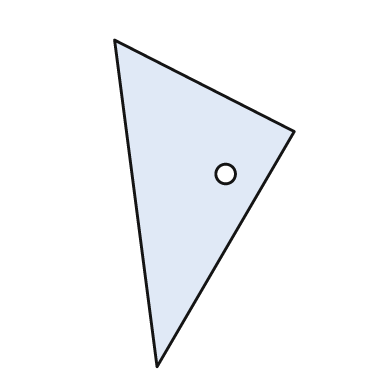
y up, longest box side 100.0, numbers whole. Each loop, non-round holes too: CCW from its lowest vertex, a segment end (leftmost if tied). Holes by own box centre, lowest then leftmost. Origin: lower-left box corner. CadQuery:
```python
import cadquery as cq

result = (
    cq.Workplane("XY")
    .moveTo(13.0, 0.0)
    .lineTo(55.0, 72.0)
    .lineTo(0.0, 100.0)
    .close()
    .moveTo(34.0, 59.0)
    .circle(3.0)
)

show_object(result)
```